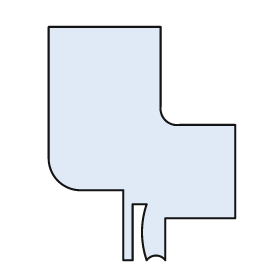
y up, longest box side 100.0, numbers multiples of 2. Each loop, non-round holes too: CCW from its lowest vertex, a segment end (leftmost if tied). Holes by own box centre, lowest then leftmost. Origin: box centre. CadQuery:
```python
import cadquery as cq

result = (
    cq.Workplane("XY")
    .moveTo(-8.0, -50.0)
    .lineTo(-4.0, -50.0)
    .lineTo(-4.0, -26.0)
    .lineTo(2.0, -26.0)
    .threePointArc((0.0, -38.0), (2.0, -50.0))
    .threePointArc((6.0, -48.0), (10.0, -50.0))
    .lineTo(10.0, -32.0)
    .lineTo(40.0, -32.0)
    .lineTo(40.0, 8.0)
    .lineTo(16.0, 8.0)
    .threePointArc((10.0, 10.0), (8.0, 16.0))
    .lineTo(8.0, 50.0)
    .lineTo(-40.0, 50.0)
    .lineTo(-40.0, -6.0)
    .threePointArc((-36.0, -16.0), (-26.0, -20.0))
    .lineTo(-8.0, -20.0)
    .close()
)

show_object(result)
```